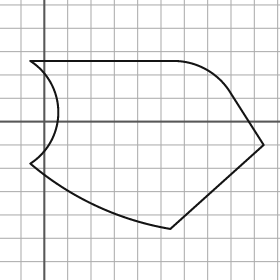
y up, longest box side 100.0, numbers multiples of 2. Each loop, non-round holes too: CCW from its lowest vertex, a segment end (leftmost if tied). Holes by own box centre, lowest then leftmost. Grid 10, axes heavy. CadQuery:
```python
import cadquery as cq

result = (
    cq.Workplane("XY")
    .moveTo(54.0, -46.0)
    .lineTo(94.0, -10.0)
    .lineTo(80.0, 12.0)
    .threePointArc((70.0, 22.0), (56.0, 26.0))
    .lineTo(-6.0, 26.0)
    .threePointArc((6.0, 4.0), (-6.0, -18.0))
    .threePointArc((22.0, -36.0), (54.0, -46.0))
    .close()
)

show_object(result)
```